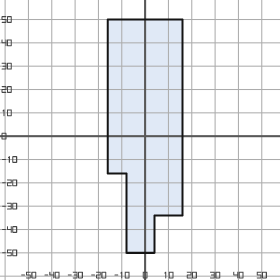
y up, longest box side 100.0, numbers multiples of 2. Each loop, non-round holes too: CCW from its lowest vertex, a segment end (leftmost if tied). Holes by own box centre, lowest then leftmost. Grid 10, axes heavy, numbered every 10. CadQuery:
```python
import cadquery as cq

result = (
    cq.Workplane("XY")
    .moveTo(-8.0, -50.0)
    .lineTo(4.0, -50.0)
    .lineTo(4.0, -34.0)
    .lineTo(16.0, -34.0)
    .lineTo(16.0, 50.0)
    .lineTo(-16.0, 50.0)
    .lineTo(-16.0, -16.0)
    .lineTo(-8.0, -16.0)
    .close()
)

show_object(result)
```